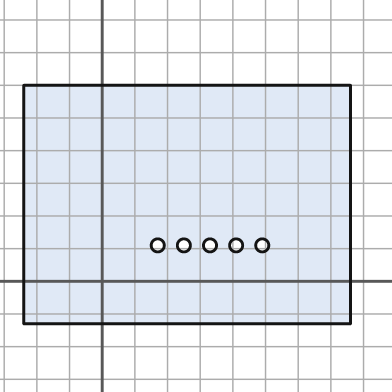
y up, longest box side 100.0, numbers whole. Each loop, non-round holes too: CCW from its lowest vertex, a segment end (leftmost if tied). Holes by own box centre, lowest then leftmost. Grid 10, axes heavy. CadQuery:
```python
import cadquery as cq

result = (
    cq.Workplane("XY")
    .moveTo(-24.0, -13.0)
    .lineTo(76.0, -13.0)
    .lineTo(76.0, 60.0)
    .lineTo(-24.0, 60.0)
    .close()
    .moveTo(17.0, 11.0)
    .circle(2.0)
    .moveTo(25.0, 11.0)
    .circle(2.0)
    .moveTo(33.0, 11.0)
    .circle(2.0)
    .moveTo(41.0, 11.0)
    .circle(2.0)
    .moveTo(49.0, 11.0)
    .circle(2.0)
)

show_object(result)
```